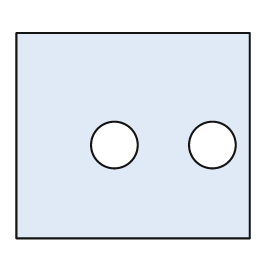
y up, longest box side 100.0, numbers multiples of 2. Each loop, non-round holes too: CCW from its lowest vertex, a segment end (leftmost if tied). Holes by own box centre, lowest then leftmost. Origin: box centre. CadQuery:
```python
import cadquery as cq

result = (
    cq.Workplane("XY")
    .moveTo(-50.0, -44.0)
    .lineTo(50.0, -44.0)
    .lineTo(50.0, 44.0)
    .lineTo(-50.0, 44.0)
    .close()
    .moveTo(-8.0, -4.0)
    .circle(10.0)
    .moveTo(34.0, -4.0)
    .circle(10.0)
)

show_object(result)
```